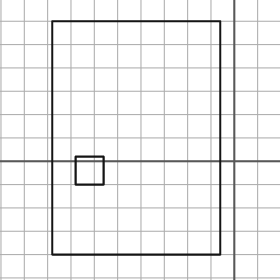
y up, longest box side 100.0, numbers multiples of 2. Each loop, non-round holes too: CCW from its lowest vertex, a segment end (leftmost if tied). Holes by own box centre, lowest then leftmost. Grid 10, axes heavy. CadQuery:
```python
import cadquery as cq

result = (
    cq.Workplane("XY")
    .moveTo(-78.0, -40.0)
    .lineTo(-6.0, -40.0)
    .lineTo(-6.0, 60.0)
    .lineTo(-78.0, 60.0)
    .close()
    .moveTo(-68.0, -10.0)
    .lineTo(-56.0, -10.0)
    .lineTo(-56.0, 2.0)
    .lineTo(-68.0, 2.0)
    .close()
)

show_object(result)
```